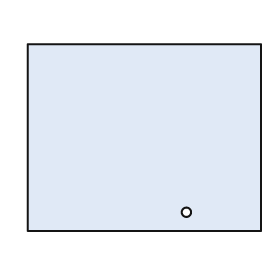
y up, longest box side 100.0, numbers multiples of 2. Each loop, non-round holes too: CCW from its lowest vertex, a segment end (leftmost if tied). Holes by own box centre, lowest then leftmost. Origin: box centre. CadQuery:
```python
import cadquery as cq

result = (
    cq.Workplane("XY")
    .moveTo(-50.0, -40.0)
    .lineTo(50.0, -40.0)
    .lineTo(50.0, 40.0)
    .lineTo(-50.0, 40.0)
    .close()
    .moveTo(18.0, -32.0)
    .circle(2.0)
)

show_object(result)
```